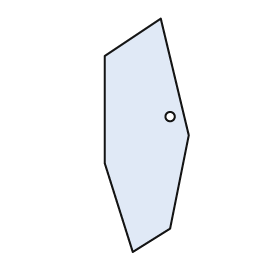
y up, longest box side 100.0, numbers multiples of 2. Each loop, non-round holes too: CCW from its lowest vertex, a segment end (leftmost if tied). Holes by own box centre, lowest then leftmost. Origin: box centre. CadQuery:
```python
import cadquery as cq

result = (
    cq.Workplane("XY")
    .moveTo(-6.0, -50.0)
    .lineTo(10.0, -40.0)
    .lineTo(18.0, 0.0)
    .lineTo(6.0, 50.0)
    .lineTo(-18.0, 34.0)
    .lineTo(-18.0, -12.0)
    .close()
    .moveTo(10.0, 8.0)
    .circle(2.0)
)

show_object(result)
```